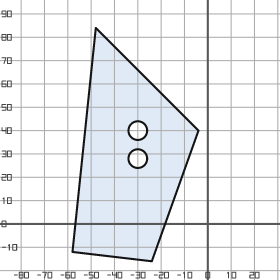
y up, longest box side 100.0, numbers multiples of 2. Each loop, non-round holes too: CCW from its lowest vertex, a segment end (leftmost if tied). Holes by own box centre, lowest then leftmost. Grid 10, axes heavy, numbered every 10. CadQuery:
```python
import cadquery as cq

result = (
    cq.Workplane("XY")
    .moveTo(-24.0, -16.0)
    .lineTo(-4.0, 40.0)
    .lineTo(-48.0, 84.0)
    .lineTo(-58.0, -12.0)
    .close()
    .moveTo(-30.0, 28.0)
    .circle(4.0)
    .moveTo(-30.0, 40.0)
    .circle(4.0)
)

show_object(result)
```